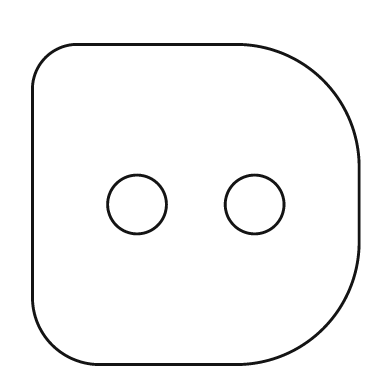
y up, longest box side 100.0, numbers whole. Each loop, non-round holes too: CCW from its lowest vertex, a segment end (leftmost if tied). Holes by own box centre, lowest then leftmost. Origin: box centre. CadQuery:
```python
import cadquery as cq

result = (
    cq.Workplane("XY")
    .moveTo(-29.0, -49.0)
    .lineTo(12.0, -49.0)
    .threePointArc((39.0, -38.0), (50.0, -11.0))
    .lineTo(50.0, 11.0)
    .threePointArc((39.0, 38.0), (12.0, 49.0))
    .lineTo(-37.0, 49.0)
    .threePointArc((-46.0, 45.0), (-50.0, 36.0))
    .lineTo(-50.0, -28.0)
    .threePointArc((-44.0, -43.0), (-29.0, -49.0))
    .close()
    .moveTo(-18.0, 0.0)
    .circle(9.0)
    .moveTo(18.0, 0.0)
    .circle(9.0)
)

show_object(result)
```